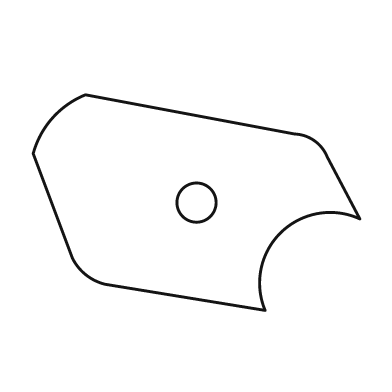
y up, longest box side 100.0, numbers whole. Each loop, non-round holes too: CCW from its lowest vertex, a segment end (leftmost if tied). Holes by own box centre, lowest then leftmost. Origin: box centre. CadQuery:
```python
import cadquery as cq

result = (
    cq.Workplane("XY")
    .moveTo(21.0, -33.0)
    .threePointArc((26.0, -9.0), (50.0, -5.0))
    .lineTo(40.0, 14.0)
    .threePointArc((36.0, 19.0), (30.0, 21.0))
    .lineTo(-34.0, 33.0)
    .threePointArc((-44.0, 26.0), (-50.0, 15.0))
    .lineTo(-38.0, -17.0)
    .threePointArc((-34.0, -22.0), (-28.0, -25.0))
    .close()
    .moveTo(0.0, 0.0)
    .circle(6.0)
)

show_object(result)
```